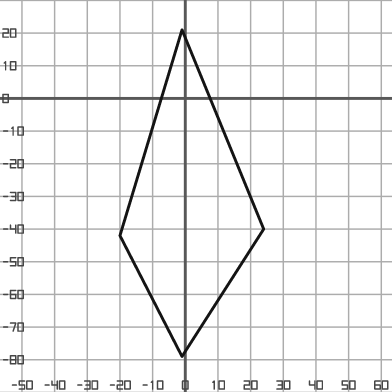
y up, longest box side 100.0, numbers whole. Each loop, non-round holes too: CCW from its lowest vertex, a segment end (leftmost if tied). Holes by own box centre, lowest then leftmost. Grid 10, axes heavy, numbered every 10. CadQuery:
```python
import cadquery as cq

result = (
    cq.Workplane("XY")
    .moveTo(-1.0, -79.0)
    .lineTo(24.0, -40.0)
    .lineTo(-1.0, 21.0)
    .lineTo(-20.0, -42.0)
    .close()
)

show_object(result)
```